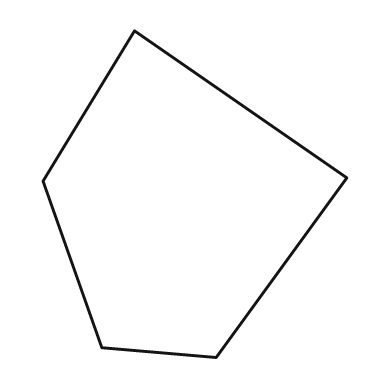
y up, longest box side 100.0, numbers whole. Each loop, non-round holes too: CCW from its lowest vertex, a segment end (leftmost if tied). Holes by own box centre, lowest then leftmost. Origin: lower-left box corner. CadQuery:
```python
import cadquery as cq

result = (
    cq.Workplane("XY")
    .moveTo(53.0, 0.0)
    .lineTo(93.0, 55.0)
    .lineTo(28.0, 100.0)
    .lineTo(0.0, 54.0)
    .lineTo(18.0, 3.0)
    .close()
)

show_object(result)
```